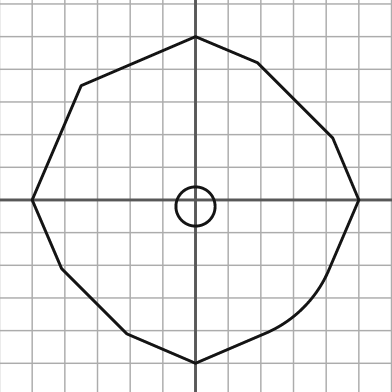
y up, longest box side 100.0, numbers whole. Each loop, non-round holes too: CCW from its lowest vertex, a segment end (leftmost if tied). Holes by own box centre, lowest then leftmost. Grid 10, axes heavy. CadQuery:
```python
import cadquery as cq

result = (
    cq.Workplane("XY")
    .moveTo(0.0, -50.0)
    .lineTo(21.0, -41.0)
    .threePointArc((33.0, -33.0), (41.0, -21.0))
    .lineTo(50.0, 0.0)
    .lineTo(42.0, 19.0)
    .lineTo(19.0, 42.0)
    .lineTo(0.0, 50.0)
    .lineTo(-35.0, 35.0)
    .lineTo(-50.0, 0.0)
    .lineTo(-41.0, -21.0)
    .lineTo(-21.0, -41.0)
    .close()
    .moveTo(0.0, -2.0)
    .circle(6.0)
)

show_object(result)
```